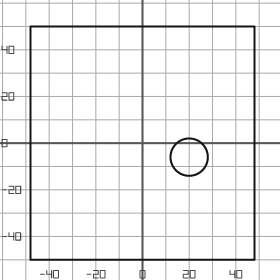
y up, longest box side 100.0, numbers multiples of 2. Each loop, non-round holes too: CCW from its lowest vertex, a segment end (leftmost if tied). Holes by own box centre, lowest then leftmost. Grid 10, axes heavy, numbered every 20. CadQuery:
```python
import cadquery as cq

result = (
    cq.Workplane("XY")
    .moveTo(-48.0, -50.0)
    .lineTo(48.0, -50.0)
    .lineTo(48.0, 50.0)
    .lineTo(-48.0, 50.0)
    .close()
    .moveTo(20.0, -6.0)
    .circle(8.0)
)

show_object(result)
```